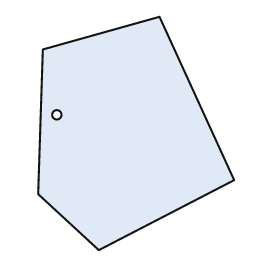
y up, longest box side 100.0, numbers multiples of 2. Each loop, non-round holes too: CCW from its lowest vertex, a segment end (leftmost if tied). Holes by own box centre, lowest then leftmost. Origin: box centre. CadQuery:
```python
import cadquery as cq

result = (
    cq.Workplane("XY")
    .moveTo(-16.0, -50.0)
    .lineTo(42.0, -20.0)
    .lineTo(10.0, 50.0)
    .lineTo(-40.0, 36.0)
    .lineTo(-42.0, -26.0)
    .close()
    .moveTo(-34.0, 8.0)
    .circle(2.0)
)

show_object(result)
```